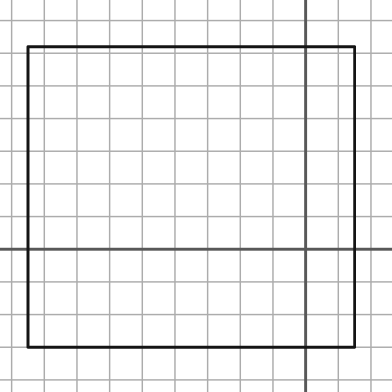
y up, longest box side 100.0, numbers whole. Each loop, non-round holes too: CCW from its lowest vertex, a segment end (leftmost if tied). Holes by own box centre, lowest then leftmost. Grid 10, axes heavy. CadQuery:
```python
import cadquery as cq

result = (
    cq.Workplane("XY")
    .moveTo(-85.0, -30.0)
    .lineTo(15.0, -30.0)
    .lineTo(15.0, 62.0)
    .lineTo(-85.0, 62.0)
    .close()
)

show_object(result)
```